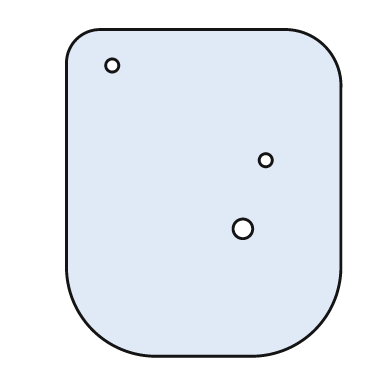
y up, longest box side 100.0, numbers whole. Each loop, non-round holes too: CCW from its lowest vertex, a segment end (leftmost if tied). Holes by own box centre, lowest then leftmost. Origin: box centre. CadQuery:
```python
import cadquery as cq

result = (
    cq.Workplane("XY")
    .moveTo(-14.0, -50.0)
    .lineTo(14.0, -50.0)
    .threePointArc((34.0, -42.0), (42.0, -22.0))
    .lineTo(42.0, 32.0)
    .threePointArc((37.0, 45.0), (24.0, 50.0))
    .lineTo(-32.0, 50.0)
    .threePointArc((-39.0, 47.0), (-42.0, 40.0))
    .lineTo(-42.0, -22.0)
    .threePointArc((-34.0, -42.0), (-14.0, -50.0))
    .close()
    .moveTo(12.0, -11.0)
    .circle(3.0)
    .moveTo(19.0, 10.0)
    .circle(2.0)
    .moveTo(-28.0, 39.0)
    .circle(2.0)
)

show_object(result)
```